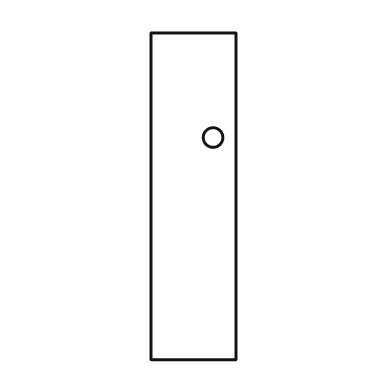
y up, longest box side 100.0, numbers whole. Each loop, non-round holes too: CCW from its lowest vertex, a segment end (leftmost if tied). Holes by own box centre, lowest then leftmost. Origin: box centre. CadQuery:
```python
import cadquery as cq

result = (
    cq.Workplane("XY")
    .moveTo(-13.0, -50.0)
    .lineTo(13.0, -50.0)
    .lineTo(13.0, 50.0)
    .lineTo(-13.0, 50.0)
    .close()
    .moveTo(6.0, 18.0)
    .circle(3.0)
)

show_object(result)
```